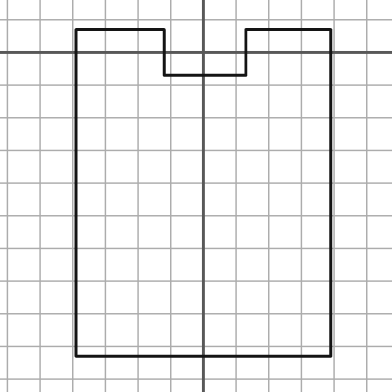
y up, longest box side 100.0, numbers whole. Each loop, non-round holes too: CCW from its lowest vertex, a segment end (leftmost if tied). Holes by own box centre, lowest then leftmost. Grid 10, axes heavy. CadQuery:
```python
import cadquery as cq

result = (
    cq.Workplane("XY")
    .moveTo(-39.0, -93.0)
    .lineTo(39.0, -93.0)
    .lineTo(39.0, 7.0)
    .lineTo(13.0, 7.0)
    .lineTo(13.0, -7.0)
    .lineTo(-12.0, -7.0)
    .lineTo(-12.0, 7.0)
    .lineTo(-39.0, 7.0)
    .close()
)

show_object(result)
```